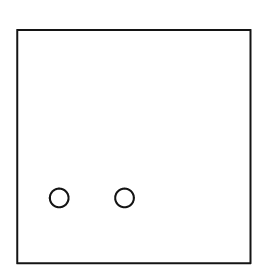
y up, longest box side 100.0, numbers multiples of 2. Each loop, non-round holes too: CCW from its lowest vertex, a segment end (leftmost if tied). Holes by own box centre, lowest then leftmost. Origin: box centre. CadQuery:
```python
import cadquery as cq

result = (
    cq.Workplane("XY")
    .moveTo(-50.0, -50.0)
    .lineTo(50.0, -50.0)
    .lineTo(50.0, 50.0)
    .lineTo(-50.0, 50.0)
    .close()
    .moveTo(-32.0, -22.0)
    .circle(4.0)
    .moveTo(-4.0, -22.0)
    .circle(4.0)
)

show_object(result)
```